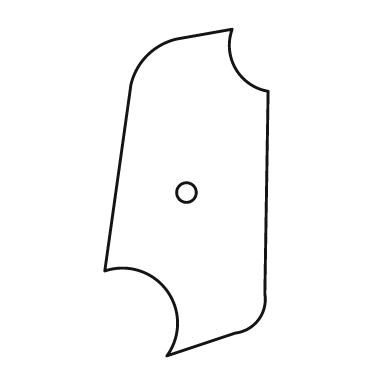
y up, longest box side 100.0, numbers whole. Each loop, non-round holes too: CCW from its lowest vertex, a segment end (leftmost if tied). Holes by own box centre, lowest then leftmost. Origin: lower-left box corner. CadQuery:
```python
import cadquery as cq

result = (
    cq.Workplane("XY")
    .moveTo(19.0, 0.0)
    .lineTo(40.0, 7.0)
    .threePointArc((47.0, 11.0), (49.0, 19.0))
    .lineTo(50.0, 81.0)
    .threePointArc((40.0, 88.0), (39.0, 100.0))
    .lineTo(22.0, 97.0)
    .threePointArc((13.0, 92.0), (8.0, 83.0))
    .lineTo(0.0, 26.0)
    .threePointArc((19.0, 20.0), (19.0, 0.0))
    .close()
    .moveTo(25.0, 50.0)
    .circle(3.0)
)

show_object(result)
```